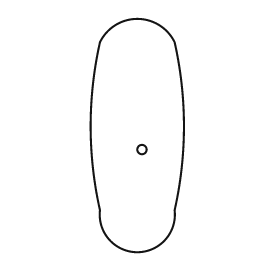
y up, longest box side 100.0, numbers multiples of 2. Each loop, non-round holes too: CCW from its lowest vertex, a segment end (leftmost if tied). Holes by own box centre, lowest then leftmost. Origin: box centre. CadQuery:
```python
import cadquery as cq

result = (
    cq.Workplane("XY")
    .moveTo(-16.0, -32.0)
    .threePointArc((0.0, -50.0), (16.0, -32.0))
    .threePointArc((20.0, 4.0), (16.0, 40.0))
    .threePointArc((0.0, 50.0), (-16.0, 40.0))
    .threePointArc((-20.0, 4.0), (-16.0, -32.0))
    .close()
    .moveTo(2.0, -6.0)
    .circle(2.0)
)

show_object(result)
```